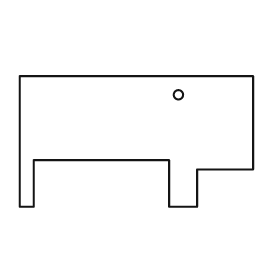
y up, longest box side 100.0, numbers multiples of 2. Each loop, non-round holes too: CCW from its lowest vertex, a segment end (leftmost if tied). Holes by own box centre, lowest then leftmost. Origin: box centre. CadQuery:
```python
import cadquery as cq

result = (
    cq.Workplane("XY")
    .moveTo(-50.0, -28.0)
    .lineTo(-44.0, -28.0)
    .lineTo(-44.0, -8.0)
    .lineTo(14.0, -8.0)
    .lineTo(14.0, -28.0)
    .lineTo(26.0, -28.0)
    .lineTo(26.0, -12.0)
    .lineTo(50.0, -12.0)
    .lineTo(50.0, 28.0)
    .lineTo(-50.0, 28.0)
    .close()
    .moveTo(18.0, 20.0)
    .circle(2.0)
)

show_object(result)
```